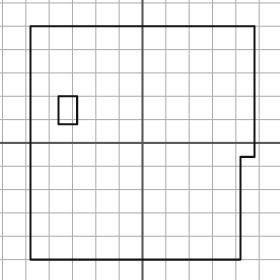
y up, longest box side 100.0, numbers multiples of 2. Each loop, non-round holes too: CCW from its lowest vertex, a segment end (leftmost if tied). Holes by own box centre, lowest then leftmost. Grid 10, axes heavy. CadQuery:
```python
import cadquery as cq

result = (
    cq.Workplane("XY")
    .moveTo(-48.0, -50.0)
    .lineTo(42.0, -50.0)
    .lineTo(42.0, -6.0)
    .lineTo(48.0, -6.0)
    .lineTo(48.0, 50.0)
    .lineTo(-48.0, 50.0)
    .close()
    .moveTo(-36.0, 8.0)
    .lineTo(-28.0, 8.0)
    .lineTo(-28.0, 20.0)
    .lineTo(-36.0, 20.0)
    .close()
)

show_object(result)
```